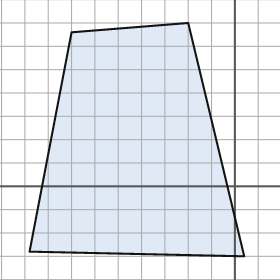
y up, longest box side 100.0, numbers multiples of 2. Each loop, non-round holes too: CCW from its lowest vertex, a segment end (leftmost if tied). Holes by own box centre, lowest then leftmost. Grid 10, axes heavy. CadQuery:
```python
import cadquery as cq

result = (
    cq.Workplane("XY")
    .moveTo(4.0, -30.0)
    .lineTo(-20.0, 70.0)
    .lineTo(-70.0, 66.0)
    .lineTo(-88.0, -28.0)
    .close()
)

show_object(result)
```